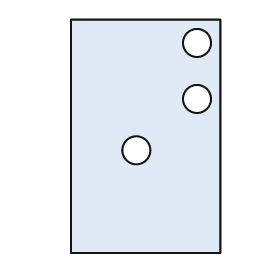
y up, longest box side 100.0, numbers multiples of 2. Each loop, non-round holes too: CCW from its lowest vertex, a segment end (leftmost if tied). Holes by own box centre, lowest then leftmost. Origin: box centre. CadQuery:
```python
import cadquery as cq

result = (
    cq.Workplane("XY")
    .moveTo(-32.0, -50.0)
    .lineTo(32.0, -50.0)
    .lineTo(32.0, 50.0)
    .lineTo(-32.0, 50.0)
    .close()
    .moveTo(-4.0, -6.0)
    .circle(6.0)
    .moveTo(22.0, 16.0)
    .circle(6.0)
    .moveTo(22.0, 40.0)
    .circle(6.0)
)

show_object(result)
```